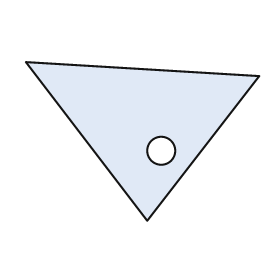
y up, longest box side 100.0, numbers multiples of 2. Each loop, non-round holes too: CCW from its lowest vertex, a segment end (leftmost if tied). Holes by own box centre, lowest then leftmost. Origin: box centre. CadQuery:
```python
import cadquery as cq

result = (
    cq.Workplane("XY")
    .moveTo(2.0, -34.0)
    .lineTo(50.0, 28.0)
    .lineTo(-50.0, 34.0)
    .close()
    .moveTo(8.0, -4.0)
    .circle(6.0)
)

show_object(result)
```